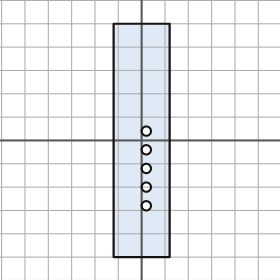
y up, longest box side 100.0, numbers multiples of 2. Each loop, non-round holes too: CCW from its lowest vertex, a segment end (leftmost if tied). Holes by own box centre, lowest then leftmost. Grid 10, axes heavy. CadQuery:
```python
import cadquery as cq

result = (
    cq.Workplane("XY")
    .moveTo(-12.0, -50.0)
    .lineTo(12.0, -50.0)
    .lineTo(12.0, 50.0)
    .lineTo(-12.0, 50.0)
    .close()
    .moveTo(2.0, -28.0)
    .circle(2.0)
    .moveTo(2.0, -20.0)
    .circle(2.0)
    .moveTo(2.0, -12.0)
    .circle(2.0)
    .moveTo(2.0, -4.0)
    .circle(2.0)
    .moveTo(2.0, 4.0)
    .circle(2.0)
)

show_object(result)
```